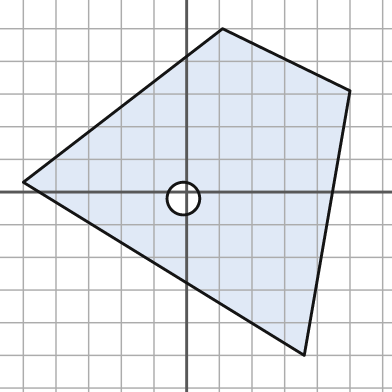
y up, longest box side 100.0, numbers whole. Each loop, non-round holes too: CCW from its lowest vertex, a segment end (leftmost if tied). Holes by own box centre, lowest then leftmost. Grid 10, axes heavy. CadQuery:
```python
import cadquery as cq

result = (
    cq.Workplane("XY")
    .moveTo(36.0, -50.0)
    .lineTo(50.0, 31.0)
    .lineTo(11.0, 50.0)
    .lineTo(-50.0, 3.0)
    .close()
    .moveTo(-1.0, -2.0)
    .circle(5.0)
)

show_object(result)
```